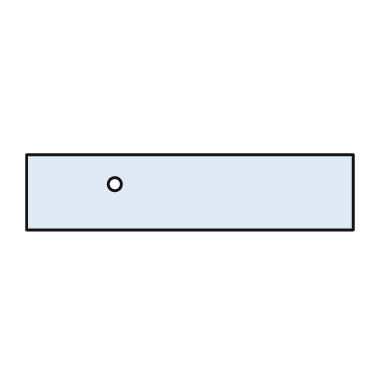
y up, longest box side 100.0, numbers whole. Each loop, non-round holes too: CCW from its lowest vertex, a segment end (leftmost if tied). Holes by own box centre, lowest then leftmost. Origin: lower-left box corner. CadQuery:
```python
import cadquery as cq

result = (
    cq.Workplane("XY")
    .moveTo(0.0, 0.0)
    .lineTo(100.0, 0.0)
    .lineTo(100.0, 23.0)
    .lineTo(0.0, 23.0)
    .close()
    .moveTo(27.0, 14.0)
    .circle(2.0)
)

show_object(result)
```